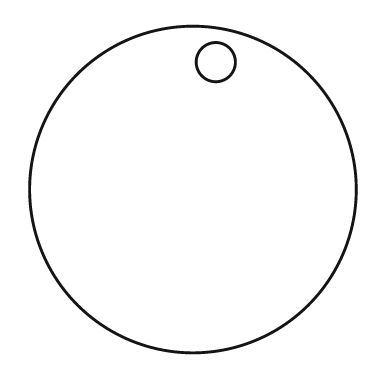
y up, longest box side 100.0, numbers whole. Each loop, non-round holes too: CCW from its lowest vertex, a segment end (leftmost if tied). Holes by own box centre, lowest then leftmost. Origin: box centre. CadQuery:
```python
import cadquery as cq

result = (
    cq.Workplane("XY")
    .moveTo(0.0, 0.0)
    .circle(50.0)
    .moveTo(7.0, 39.0)
    .circle(6.0)
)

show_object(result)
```